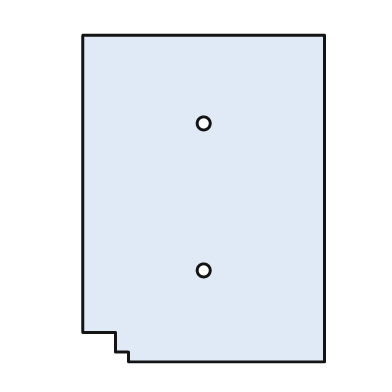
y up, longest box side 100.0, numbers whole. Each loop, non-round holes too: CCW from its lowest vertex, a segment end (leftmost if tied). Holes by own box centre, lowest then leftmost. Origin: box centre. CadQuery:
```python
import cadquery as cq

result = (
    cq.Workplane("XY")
    .moveTo(-23.0, -50.0)
    .lineTo(37.0, -50.0)
    .lineTo(37.0, 50.0)
    .lineTo(-37.0, 50.0)
    .lineTo(-37.0, -41.0)
    .lineTo(-27.0, -41.0)
    .lineTo(-27.0, -47.0)
    .lineTo(-23.0, -47.0)
    .close()
    .moveTo(0.0, -22.0)
    .circle(2.0)
    .moveTo(0.0, 23.0)
    .circle(2.0)
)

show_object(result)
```